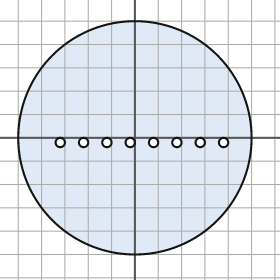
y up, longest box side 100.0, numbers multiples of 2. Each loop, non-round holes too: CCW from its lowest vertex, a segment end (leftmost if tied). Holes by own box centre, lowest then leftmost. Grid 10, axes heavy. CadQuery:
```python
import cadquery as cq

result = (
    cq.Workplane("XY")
    .moveTo(0.0, 0.0)
    .circle(50.0)
    .moveTo(-32.0, -2.0)
    .circle(2.0)
    .moveTo(-22.0, -2.0)
    .circle(2.0)
    .moveTo(-12.0, -2.0)
    .circle(2.0)
    .moveTo(-2.0, -2.0)
    .circle(2.0)
    .moveTo(8.0, -2.0)
    .circle(2.0)
    .moveTo(18.0, -2.0)
    .circle(2.0)
    .moveTo(28.0, -2.0)
    .circle(2.0)
    .moveTo(38.0, -2.0)
    .circle(2.0)
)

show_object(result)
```